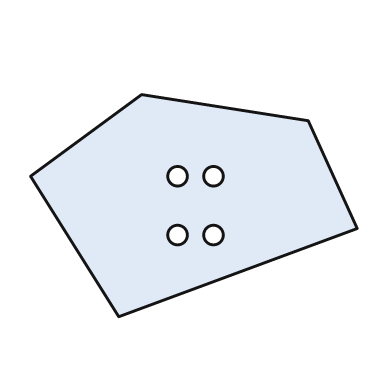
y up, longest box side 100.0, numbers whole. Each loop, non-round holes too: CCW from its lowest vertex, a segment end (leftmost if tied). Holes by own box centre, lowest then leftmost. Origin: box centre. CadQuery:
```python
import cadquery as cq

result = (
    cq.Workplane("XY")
    .moveTo(-23.0, -34.0)
    .lineTo(50.0, -7.0)
    .lineTo(35.0, 26.0)
    .lineTo(-16.0, 34.0)
    .lineTo(-50.0, 9.0)
    .close()
    .moveTo(-5.0, -9.0)
    .circle(3.0)
    .moveTo(6.0, -9.0)
    .circle(3.0)
    .moveTo(-5.0, 9.0)
    .circle(3.0)
    .moveTo(6.0, 9.0)
    .circle(3.0)
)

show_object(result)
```